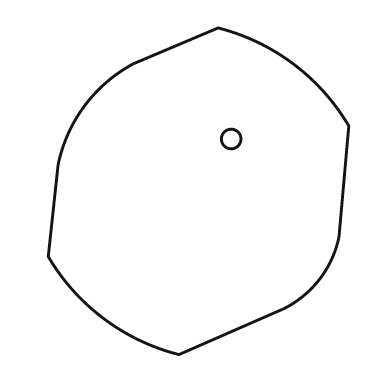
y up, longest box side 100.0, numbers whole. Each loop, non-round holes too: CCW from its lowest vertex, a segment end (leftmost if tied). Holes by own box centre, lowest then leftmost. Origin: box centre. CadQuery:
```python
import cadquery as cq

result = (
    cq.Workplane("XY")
    .moveTo(-6.0, -50.0)
    .lineTo(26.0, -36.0)
    .threePointArc((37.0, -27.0), (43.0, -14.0))
    .lineTo(46.0, 20.0)
    .threePointArc((29.0, 39.0), (6.0, 50.0))
    .lineTo(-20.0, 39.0)
    .threePointArc((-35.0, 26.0), (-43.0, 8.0))
    .lineTo(-46.0, -20.0)
    .threePointArc((-29.0, -39.0), (-6.0, -50.0))
    .close()
    .moveTo(10.0, 16.0)
    .circle(3.0)
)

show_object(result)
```